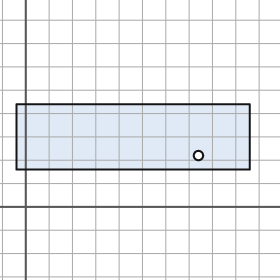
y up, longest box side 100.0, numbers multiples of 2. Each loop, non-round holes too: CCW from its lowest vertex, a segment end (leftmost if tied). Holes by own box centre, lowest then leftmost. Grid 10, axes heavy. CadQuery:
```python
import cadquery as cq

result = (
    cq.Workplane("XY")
    .moveTo(-4.0, 16.0)
    .lineTo(96.0, 16.0)
    .lineTo(96.0, 44.0)
    .lineTo(-4.0, 44.0)
    .close()
    .moveTo(74.0, 22.0)
    .circle(2.0)
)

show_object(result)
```